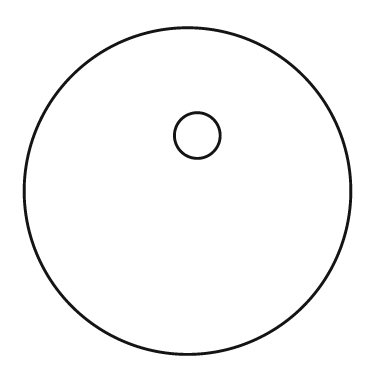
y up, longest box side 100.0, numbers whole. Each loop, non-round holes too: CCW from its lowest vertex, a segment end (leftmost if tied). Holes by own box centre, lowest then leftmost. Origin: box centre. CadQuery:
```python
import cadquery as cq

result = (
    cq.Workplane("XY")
    .moveTo(0.0, 0.0)
    .circle(50.0)
    .moveTo(3.0, 17.0)
    .circle(7.0)
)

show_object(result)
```